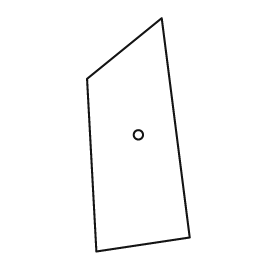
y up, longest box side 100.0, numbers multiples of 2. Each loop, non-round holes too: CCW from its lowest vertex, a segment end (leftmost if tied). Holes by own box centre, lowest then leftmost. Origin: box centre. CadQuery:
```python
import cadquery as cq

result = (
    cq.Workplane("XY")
    .moveTo(-18.0, -50.0)
    .lineTo(22.0, -44.0)
    .lineTo(10.0, 50.0)
    .lineTo(-22.0, 24.0)
    .close()
    .moveTo(0.0, 0.0)
    .circle(2.0)
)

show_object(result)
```